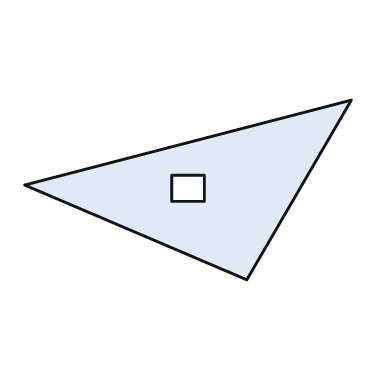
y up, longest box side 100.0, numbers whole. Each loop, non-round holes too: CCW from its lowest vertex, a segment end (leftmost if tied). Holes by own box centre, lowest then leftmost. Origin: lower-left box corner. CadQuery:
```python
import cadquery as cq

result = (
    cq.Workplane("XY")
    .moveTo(68.0, 0.0)
    .lineTo(100.0, 55.0)
    .lineTo(0.0, 29.0)
    .close()
    .moveTo(45.0, 24.0)
    .lineTo(55.0, 24.0)
    .lineTo(55.0, 32.0)
    .lineTo(45.0, 32.0)
    .close()
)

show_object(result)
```